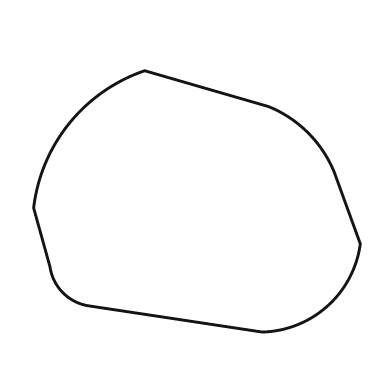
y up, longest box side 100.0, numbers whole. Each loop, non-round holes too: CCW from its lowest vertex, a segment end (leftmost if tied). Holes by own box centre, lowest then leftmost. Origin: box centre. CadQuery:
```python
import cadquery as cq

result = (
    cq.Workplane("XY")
    .moveTo(20.0, -40.0)
    .threePointArc((40.0, -32.0), (50.0, -13.0))
    .lineTo(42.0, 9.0)
    .threePointArc((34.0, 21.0), (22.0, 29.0))
    .lineTo(-16.0, 40.0)
    .threePointArc((-39.0, 24.0), (-50.0, -2.0))
    .lineTo(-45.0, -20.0)
    .threePointArc((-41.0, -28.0), (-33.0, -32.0))
    .close()
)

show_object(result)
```